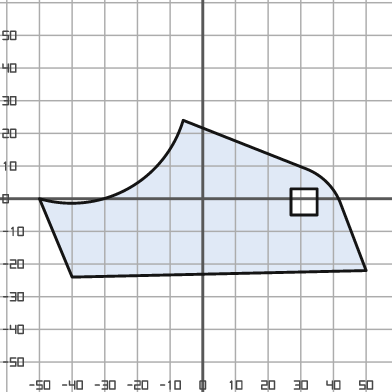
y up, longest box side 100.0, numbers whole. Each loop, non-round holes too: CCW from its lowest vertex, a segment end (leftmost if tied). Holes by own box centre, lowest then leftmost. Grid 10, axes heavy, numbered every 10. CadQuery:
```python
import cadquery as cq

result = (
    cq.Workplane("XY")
    .moveTo(-40.0, -24.0)
    .lineTo(50.0, -22.0)
    .lineTo(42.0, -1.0)
    .threePointArc((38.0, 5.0), (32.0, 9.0))
    .lineTo(-6.0, 24.0)
    .threePointArc((-23.0, 3.0), (-50.0, 0.0))
    .close()
    .moveTo(27.0, -5.0)
    .lineTo(35.0, -5.0)
    .lineTo(35.0, 3.0)
    .lineTo(27.0, 3.0)
    .close()
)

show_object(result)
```